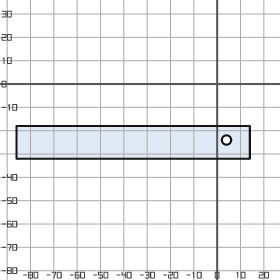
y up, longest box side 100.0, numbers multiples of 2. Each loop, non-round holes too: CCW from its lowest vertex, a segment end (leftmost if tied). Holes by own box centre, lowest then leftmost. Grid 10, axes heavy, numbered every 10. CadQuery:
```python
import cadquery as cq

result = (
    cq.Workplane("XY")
    .moveTo(-86.0, -32.0)
    .lineTo(14.0, -32.0)
    .lineTo(14.0, -18.0)
    .lineTo(-86.0, -18.0)
    .close()
    .moveTo(4.0, -24.0)
    .circle(2.0)
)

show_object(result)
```